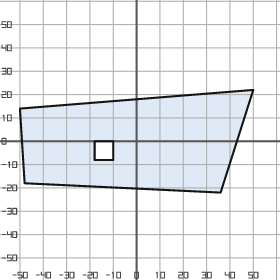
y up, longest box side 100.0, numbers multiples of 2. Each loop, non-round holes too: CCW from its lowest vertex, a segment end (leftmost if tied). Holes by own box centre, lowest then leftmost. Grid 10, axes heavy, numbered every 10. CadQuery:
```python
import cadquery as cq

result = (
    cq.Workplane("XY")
    .moveTo(36.0, -22.0)
    .lineTo(50.0, 22.0)
    .lineTo(-50.0, 14.0)
    .lineTo(-48.0, -18.0)
    .close()
    .moveTo(-18.0, -8.0)
    .lineTo(-10.0, -8.0)
    .lineTo(-10.0, 0.0)
    .lineTo(-18.0, 0.0)
    .close()
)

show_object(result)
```